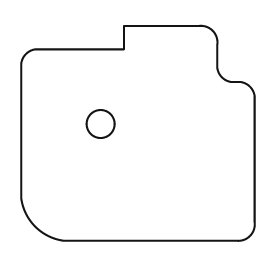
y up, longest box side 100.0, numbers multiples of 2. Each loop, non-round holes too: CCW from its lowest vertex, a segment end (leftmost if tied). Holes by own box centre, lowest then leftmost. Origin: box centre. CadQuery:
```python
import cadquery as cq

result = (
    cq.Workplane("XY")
    .moveTo(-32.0, -46.0)
    .lineTo(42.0, -46.0)
    .threePointArc((48.0, -44.0), (50.0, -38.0))
    .lineTo(50.0, 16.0)
    .threePointArc((48.0, 20.0), (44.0, 22.0))
    .lineTo(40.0, 22.0)
    .threePointArc((36.0, 24.0), (34.0, 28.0))
    .lineTo(34.0, 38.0)
    .threePointArc((32.0, 44.0), (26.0, 46.0))
    .lineTo(-6.0, 46.0)
    .lineTo(-6.0, 36.0)
    .lineTo(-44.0, 36.0)
    .threePointArc((-48.0, 34.0), (-50.0, 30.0))
    .lineTo(-50.0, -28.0)
    .threePointArc((-44.0, -40.0), (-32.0, -46.0))
    .close()
    .moveTo(-16.0, 4.0)
    .circle(6.0)
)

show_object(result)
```